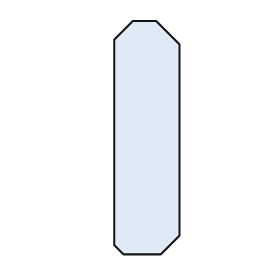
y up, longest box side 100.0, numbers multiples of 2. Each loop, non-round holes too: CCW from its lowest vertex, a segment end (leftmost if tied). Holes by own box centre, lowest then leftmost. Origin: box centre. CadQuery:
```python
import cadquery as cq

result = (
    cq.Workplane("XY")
    .moveTo(-10.0, -50.0)
    .lineTo(6.0, -50.0)
    .lineTo(14.0, -42.0)
    .lineTo(14.0, 40.0)
    .lineTo(4.0, 50.0)
    .lineTo(-6.0, 50.0)
    .lineTo(-14.0, 42.0)
    .lineTo(-14.0, -46.0)
    .close()
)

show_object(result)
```